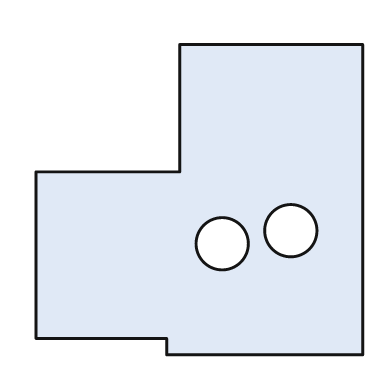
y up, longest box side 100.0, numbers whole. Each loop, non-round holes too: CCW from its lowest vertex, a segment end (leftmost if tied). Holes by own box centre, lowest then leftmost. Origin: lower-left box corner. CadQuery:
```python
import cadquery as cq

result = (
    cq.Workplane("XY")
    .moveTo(40.0, 0.0)
    .lineTo(100.0, 0.0)
    .lineTo(100.0, 95.0)
    .lineTo(44.0, 95.0)
    .lineTo(44.0, 56.0)
    .lineTo(0.0, 56.0)
    .lineTo(0.0, 5.0)
    .lineTo(40.0, 5.0)
    .close()
    .moveTo(57.0, 34.0)
    .circle(8.0)
    .moveTo(78.0, 38.0)
    .circle(8.0)
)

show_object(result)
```